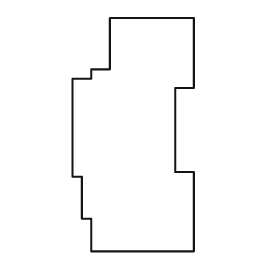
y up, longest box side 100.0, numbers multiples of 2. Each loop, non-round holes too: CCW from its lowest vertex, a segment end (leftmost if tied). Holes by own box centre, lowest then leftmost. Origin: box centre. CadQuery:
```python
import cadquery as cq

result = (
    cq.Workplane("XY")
    .moveTo(-18.0, -50.0)
    .lineTo(26.0, -50.0)
    .lineTo(26.0, -16.0)
    .lineTo(18.0, -16.0)
    .lineTo(18.0, 20.0)
    .lineTo(26.0, 20.0)
    .lineTo(26.0, 50.0)
    .lineTo(-10.0, 50.0)
    .lineTo(-10.0, 28.0)
    .lineTo(-18.0, 28.0)
    .lineTo(-18.0, 24.0)
    .lineTo(-26.0, 24.0)
    .lineTo(-26.0, -18.0)
    .lineTo(-22.0, -18.0)
    .lineTo(-22.0, -36.0)
    .lineTo(-18.0, -36.0)
    .close()
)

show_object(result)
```